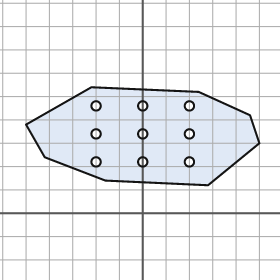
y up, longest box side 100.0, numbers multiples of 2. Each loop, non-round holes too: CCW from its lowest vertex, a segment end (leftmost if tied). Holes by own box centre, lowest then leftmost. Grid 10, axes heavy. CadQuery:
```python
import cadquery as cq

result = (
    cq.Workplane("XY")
    .moveTo(28.0, 12.0)
    .lineTo(50.0, 30.0)
    .lineTo(46.0, 42.0)
    .lineTo(24.0, 52.0)
    .lineTo(-22.0, 54.0)
    .lineTo(-50.0, 38.0)
    .lineTo(-42.0, 24.0)
    .lineTo(-16.0, 14.0)
    .close()
    .moveTo(-20.0, 22.0)
    .circle(2.0)
    .moveTo(0.0, 22.0)
    .circle(2.0)
    .moveTo(20.0, 22.0)
    .circle(2.0)
    .moveTo(-20.0, 34.0)
    .circle(2.0)
    .moveTo(0.0, 34.0)
    .circle(2.0)
    .moveTo(20.0, 34.0)
    .circle(2.0)
    .moveTo(-20.0, 46.0)
    .circle(2.0)
    .moveTo(0.0, 46.0)
    .circle(2.0)
    .moveTo(20.0, 46.0)
    .circle(2.0)
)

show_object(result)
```